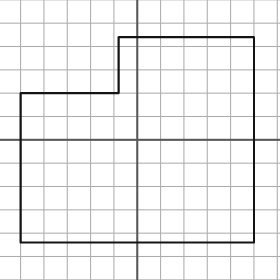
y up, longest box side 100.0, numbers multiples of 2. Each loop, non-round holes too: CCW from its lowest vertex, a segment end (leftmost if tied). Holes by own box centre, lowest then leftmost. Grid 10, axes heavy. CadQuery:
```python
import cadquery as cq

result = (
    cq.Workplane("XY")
    .moveTo(-50.0, -44.0)
    .lineTo(50.0, -44.0)
    .lineTo(50.0, 44.0)
    .lineTo(-8.0, 44.0)
    .lineTo(-8.0, 20.0)
    .lineTo(-50.0, 20.0)
    .close()
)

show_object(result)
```